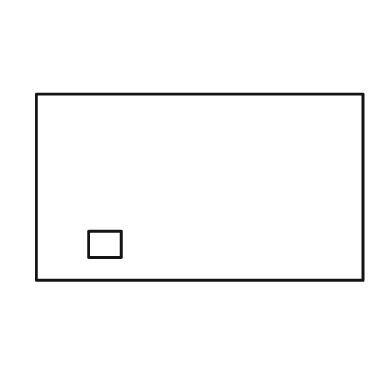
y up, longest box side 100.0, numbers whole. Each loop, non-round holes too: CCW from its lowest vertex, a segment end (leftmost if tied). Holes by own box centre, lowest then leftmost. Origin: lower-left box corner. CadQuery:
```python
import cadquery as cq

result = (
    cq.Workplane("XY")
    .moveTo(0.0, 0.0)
    .lineTo(100.0, 0.0)
    .lineTo(100.0, 57.0)
    .lineTo(0.0, 57.0)
    .close()
    .moveTo(16.0, 7.0)
    .lineTo(26.0, 7.0)
    .lineTo(26.0, 15.0)
    .lineTo(16.0, 15.0)
    .close()
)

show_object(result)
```